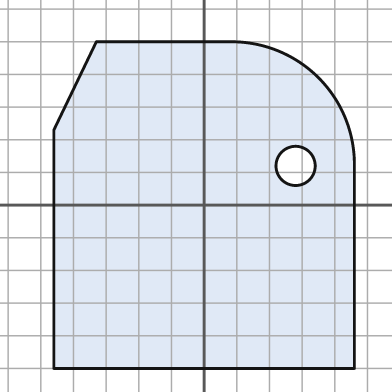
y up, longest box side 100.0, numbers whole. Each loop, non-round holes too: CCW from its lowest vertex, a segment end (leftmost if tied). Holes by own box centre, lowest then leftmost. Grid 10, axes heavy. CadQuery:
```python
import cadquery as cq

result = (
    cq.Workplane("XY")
    .moveTo(-46.0, -50.0)
    .lineTo(46.0, -50.0)
    .lineTo(46.0, 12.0)
    .threePointArc((35.0, 39.0), (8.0, 50.0))
    .lineTo(-33.0, 50.0)
    .lineTo(-46.0, 23.0)
    .close()
    .moveTo(28.0, 12.0)
    .circle(6.0)
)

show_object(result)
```